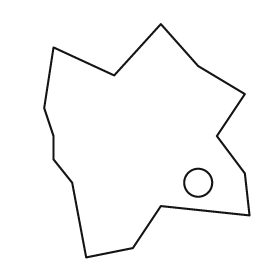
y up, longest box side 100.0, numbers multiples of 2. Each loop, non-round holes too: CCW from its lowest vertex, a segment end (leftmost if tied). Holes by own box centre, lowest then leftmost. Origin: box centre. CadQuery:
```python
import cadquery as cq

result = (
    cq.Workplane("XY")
    .moveTo(-26.0, -50.0)
    .lineTo(-6.0, -46.0)
    .lineTo(6.0, -28.0)
    .lineTo(44.0, -32.0)
    .lineTo(42.0, -14.0)
    .lineTo(30.0, 2.0)
    .lineTo(42.0, 20.0)
    .lineTo(22.0, 32.0)
    .lineTo(6.0, 50.0)
    .lineTo(-14.0, 28.0)
    .lineTo(-40.0, 40.0)
    .lineTo(-44.0, 14.0)
    .lineTo(-40.0, 2.0)
    .lineTo(-40.0, -8.0)
    .lineTo(-32.0, -18.0)
    .close()
    .moveTo(22.0, -18.0)
    .circle(6.0)
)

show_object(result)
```